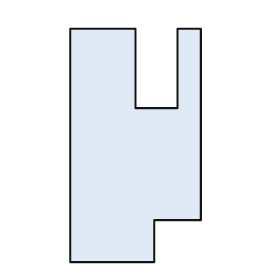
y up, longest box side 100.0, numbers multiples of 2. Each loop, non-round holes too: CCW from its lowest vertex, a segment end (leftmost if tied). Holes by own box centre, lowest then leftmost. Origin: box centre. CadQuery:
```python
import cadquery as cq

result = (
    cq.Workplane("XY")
    .moveTo(-28.0, -50.0)
    .lineTo(8.0, -50.0)
    .lineTo(8.0, -32.0)
    .lineTo(28.0, -32.0)
    .lineTo(28.0, 50.0)
    .lineTo(18.0, 50.0)
    .lineTo(18.0, 16.0)
    .lineTo(0.0, 16.0)
    .lineTo(0.0, 50.0)
    .lineTo(-28.0, 50.0)
    .close()
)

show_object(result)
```